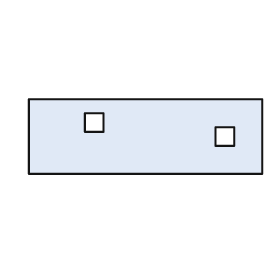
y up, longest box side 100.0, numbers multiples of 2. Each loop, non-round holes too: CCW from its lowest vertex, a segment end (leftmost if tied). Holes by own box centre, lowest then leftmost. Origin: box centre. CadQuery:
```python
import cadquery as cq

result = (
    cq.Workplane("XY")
    .moveTo(-50.0, -16.0)
    .lineTo(50.0, -16.0)
    .lineTo(50.0, 16.0)
    .lineTo(-50.0, 16.0)
    .close()
    .moveTo(30.0, -4.0)
    .lineTo(38.0, -4.0)
    .lineTo(38.0, 4.0)
    .lineTo(30.0, 4.0)
    .close()
    .moveTo(-26.0, 2.0)
    .lineTo(-18.0, 2.0)
    .lineTo(-18.0, 10.0)
    .lineTo(-26.0, 10.0)
    .close()
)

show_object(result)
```